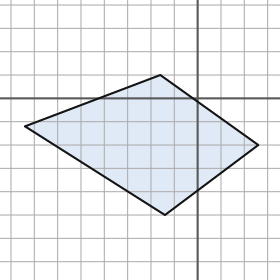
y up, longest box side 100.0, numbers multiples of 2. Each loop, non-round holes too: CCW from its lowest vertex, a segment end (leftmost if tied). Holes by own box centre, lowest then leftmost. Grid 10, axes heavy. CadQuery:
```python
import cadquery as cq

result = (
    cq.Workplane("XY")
    .moveTo(-14.0, -50.0)
    .lineTo(26.0, -20.0)
    .lineTo(-16.0, 10.0)
    .lineTo(-74.0, -12.0)
    .close()
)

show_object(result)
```